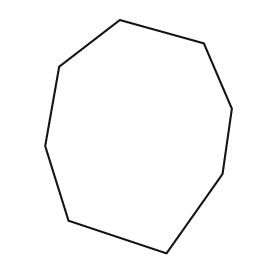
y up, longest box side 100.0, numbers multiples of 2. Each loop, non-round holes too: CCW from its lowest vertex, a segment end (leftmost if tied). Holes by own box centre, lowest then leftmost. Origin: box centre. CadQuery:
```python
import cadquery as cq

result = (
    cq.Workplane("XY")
    .moveTo(12.0, -50.0)
    .lineTo(36.0, -16.0)
    .lineTo(40.0, 12.0)
    .lineTo(28.0, 40.0)
    .lineTo(-8.0, 50.0)
    .lineTo(-34.0, 30.0)
    .lineTo(-40.0, -4.0)
    .lineTo(-30.0, -36.0)
    .close()
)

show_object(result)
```